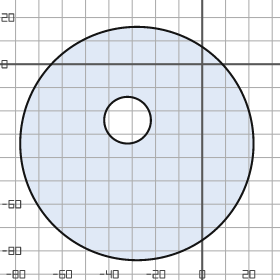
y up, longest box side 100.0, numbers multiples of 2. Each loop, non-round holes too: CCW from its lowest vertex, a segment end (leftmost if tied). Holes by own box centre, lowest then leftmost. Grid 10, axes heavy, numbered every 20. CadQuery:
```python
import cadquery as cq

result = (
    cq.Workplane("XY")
    .moveTo(-28.0, -34.0)
    .circle(50.0)
    .moveTo(-32.0, -24.0)
    .circle(10.0)
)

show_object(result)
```